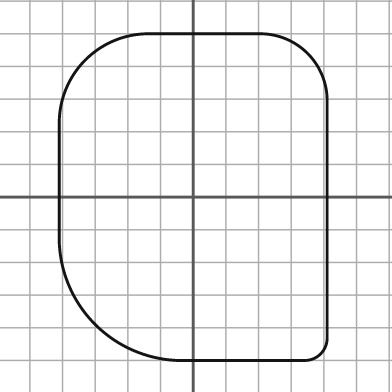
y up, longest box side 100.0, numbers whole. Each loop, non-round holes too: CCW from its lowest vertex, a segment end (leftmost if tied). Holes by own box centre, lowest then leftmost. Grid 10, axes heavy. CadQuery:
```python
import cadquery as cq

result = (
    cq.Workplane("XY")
    .moveTo(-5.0, -50.0)
    .lineTo(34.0, -50.0)
    .threePointArc((39.0, -48.0), (41.0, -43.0))
    .lineTo(41.0, 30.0)
    .threePointArc((35.0, 44.0), (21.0, 50.0))
    .lineTo(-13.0, 50.0)
    .threePointArc((-33.0, 42.0), (-41.0, 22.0))
    .lineTo(-41.0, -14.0)
    .threePointArc((-30.0, -39.0), (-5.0, -50.0))
    .close()
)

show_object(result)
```